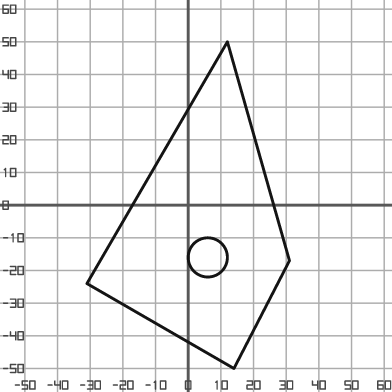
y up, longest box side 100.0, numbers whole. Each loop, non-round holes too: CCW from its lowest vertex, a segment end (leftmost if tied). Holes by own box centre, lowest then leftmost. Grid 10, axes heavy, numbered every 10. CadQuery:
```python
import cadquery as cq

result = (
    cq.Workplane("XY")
    .moveTo(14.0, -50.0)
    .lineTo(31.0, -17.0)
    .lineTo(12.0, 50.0)
    .lineTo(-31.0, -24.0)
    .close()
    .moveTo(6.0, -16.0)
    .circle(6.0)
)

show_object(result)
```